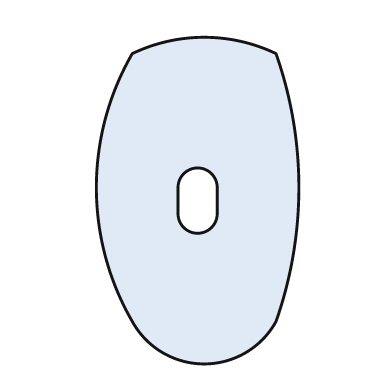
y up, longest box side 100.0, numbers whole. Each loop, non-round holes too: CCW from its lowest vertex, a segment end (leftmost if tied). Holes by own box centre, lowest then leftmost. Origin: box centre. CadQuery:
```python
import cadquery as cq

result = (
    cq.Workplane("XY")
    .moveTo(-20.0, -37.0)
    .threePointArc((2.0, -50.0), (24.0, -37.0))
    .threePointArc((31.0, 4.0), (24.0, 45.0))
    .threePointArc((2.0, 50.0), (-20.0, 45.0))
    .threePointArc((-31.0, 4.0), (-20.0, -37.0))
    .close()
    .moveTo(-6.0, -4.0)
    .threePointArc((0.0, -10.0), (6.0, -4.0))
    .lineTo(6.0, 4.0)
    .threePointArc((0.0, 10.0), (-6.0, 4.0))
    .close()
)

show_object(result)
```